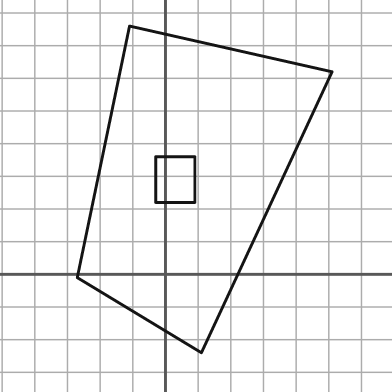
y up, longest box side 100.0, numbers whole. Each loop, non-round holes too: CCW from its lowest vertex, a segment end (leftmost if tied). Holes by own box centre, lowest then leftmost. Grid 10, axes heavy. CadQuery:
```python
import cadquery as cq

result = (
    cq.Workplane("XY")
    .moveTo(11.0, -24.0)
    .lineTo(51.0, 62.0)
    .lineTo(-11.0, 76.0)
    .lineTo(-27.0, -1.0)
    .close()
    .moveTo(-3.0, 22.0)
    .lineTo(9.0, 22.0)
    .lineTo(9.0, 36.0)
    .lineTo(-3.0, 36.0)
    .close()
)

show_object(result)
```